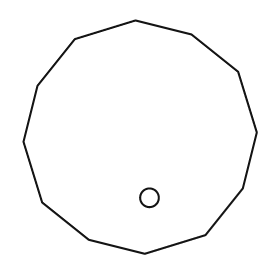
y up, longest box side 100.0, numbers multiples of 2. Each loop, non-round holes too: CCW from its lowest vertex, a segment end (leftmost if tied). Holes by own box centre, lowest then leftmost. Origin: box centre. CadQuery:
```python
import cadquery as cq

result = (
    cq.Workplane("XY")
    .moveTo(2.0, -50.0)
    .lineTo(28.0, -42.0)
    .lineTo(44.0, -22.0)
    .lineTo(50.0, 2.0)
    .lineTo(42.0, 28.0)
    .lineTo(22.0, 44.0)
    .lineTo(-2.0, 50.0)
    .lineTo(-28.0, 42.0)
    .lineTo(-44.0, 22.0)
    .lineTo(-50.0, -2.0)
    .lineTo(-42.0, -28.0)
    .lineTo(-22.0, -44.0)
    .close()
    .moveTo(4.0, -26.0)
    .circle(4.0)
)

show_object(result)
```